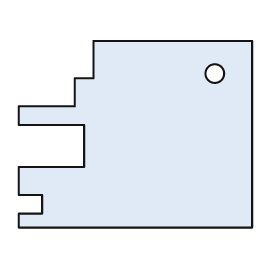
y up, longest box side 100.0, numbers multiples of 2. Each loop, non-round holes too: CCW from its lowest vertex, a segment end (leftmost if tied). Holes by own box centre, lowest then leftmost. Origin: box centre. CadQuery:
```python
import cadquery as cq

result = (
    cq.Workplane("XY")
    .moveTo(-50.0, -40.0)
    .lineTo(50.0, -40.0)
    .lineTo(50.0, 40.0)
    .lineTo(-18.0, 40.0)
    .lineTo(-18.0, 24.0)
    .lineTo(-26.0, 24.0)
    .lineTo(-26.0, 12.0)
    .lineTo(-50.0, 12.0)
    .lineTo(-50.0, 4.0)
    .lineTo(-22.0, 4.0)
    .lineTo(-22.0, -14.0)
    .lineTo(-50.0, -14.0)
    .lineTo(-50.0, -26.0)
    .lineTo(-40.0, -26.0)
    .lineTo(-40.0, -34.0)
    .lineTo(-50.0, -34.0)
    .close()
    .moveTo(34.0, 26.0)
    .circle(4.0)
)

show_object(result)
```